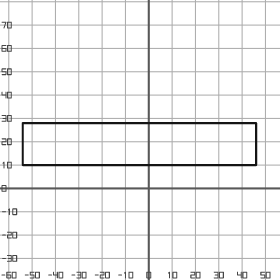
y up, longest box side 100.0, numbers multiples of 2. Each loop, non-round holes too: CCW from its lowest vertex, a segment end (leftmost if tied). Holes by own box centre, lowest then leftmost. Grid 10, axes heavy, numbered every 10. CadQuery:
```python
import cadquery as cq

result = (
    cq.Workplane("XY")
    .moveTo(-54.0, 10.0)
    .lineTo(46.0, 10.0)
    .lineTo(46.0, 28.0)
    .lineTo(-54.0, 28.0)
    .close()
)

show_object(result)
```